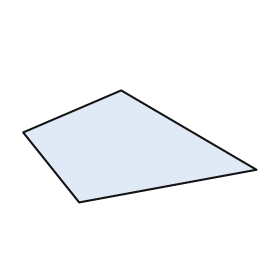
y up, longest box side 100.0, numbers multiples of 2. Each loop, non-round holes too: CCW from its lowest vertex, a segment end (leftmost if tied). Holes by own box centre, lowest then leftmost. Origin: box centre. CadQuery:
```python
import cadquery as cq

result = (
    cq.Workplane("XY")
    .moveTo(-26.0, -24.0)
    .lineTo(50.0, -10.0)
    .lineTo(-8.0, 24.0)
    .lineTo(-50.0, 6.0)
    .close()
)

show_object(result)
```